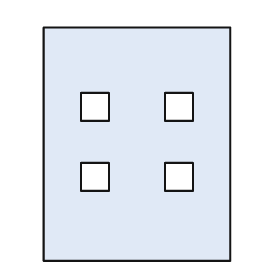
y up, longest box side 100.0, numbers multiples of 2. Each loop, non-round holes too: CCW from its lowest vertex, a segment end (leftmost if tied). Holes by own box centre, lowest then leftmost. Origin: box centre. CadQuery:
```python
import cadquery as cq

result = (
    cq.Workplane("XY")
    .moveTo(-40.0, -50.0)
    .lineTo(40.0, -50.0)
    .lineTo(40.0, 50.0)
    .lineTo(-40.0, 50.0)
    .close()
    .moveTo(-24.0, -20.0)
    .lineTo(-12.0, -20.0)
    .lineTo(-12.0, -8.0)
    .lineTo(-24.0, -8.0)
    .close()
    .moveTo(12.0, -20.0)
    .lineTo(24.0, -20.0)
    .lineTo(24.0, -8.0)
    .lineTo(12.0, -8.0)
    .close()
    .moveTo(-24.0, 10.0)
    .lineTo(-12.0, 10.0)
    .lineTo(-12.0, 22.0)
    .lineTo(-24.0, 22.0)
    .close()
    .moveTo(12.0, 10.0)
    .lineTo(24.0, 10.0)
    .lineTo(24.0, 22.0)
    .lineTo(12.0, 22.0)
    .close()
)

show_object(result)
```